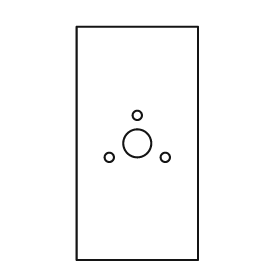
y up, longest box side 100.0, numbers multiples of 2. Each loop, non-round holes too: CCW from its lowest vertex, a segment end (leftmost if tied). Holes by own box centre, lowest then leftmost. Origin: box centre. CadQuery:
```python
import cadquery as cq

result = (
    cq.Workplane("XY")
    .moveTo(-26.0, -50.0)
    .lineTo(26.0, -50.0)
    .lineTo(26.0, 50.0)
    .lineTo(-26.0, 50.0)
    .close()
    .moveTo(-12.0, -6.0)
    .circle(2.0)
    .moveTo(12.0, -6.0)
    .circle(2.0)
    .moveTo(0.0, 0.0)
    .circle(6.0)
    .moveTo(0.0, 12.0)
    .circle(2.0)
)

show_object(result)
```